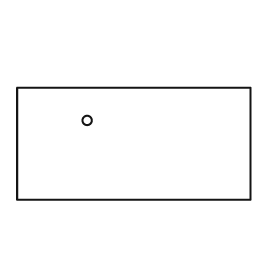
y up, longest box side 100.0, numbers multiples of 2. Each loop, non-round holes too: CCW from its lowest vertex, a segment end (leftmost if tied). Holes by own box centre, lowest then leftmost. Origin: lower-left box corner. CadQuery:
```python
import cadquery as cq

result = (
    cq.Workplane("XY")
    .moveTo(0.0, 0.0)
    .lineTo(100.0, 0.0)
    .lineTo(100.0, 48.0)
    .lineTo(0.0, 48.0)
    .close()
    .moveTo(30.0, 34.0)
    .circle(2.0)
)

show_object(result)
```